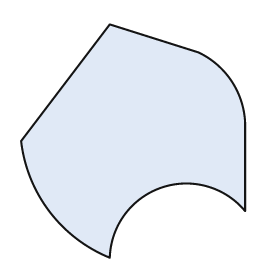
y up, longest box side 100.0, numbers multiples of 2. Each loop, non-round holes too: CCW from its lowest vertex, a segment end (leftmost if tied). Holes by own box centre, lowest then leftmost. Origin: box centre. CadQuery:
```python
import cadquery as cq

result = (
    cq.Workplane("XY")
    .moveTo(-10.0, -50.0)
    .threePointArc((12.0, -20.0), (48.0, -30.0))
    .lineTo(48.0, 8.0)
    .threePointArc((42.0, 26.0), (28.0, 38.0))
    .lineTo(-10.0, 50.0)
    .lineTo(-48.0, 0.0)
    .threePointArc((-36.0, -30.0), (-10.0, -50.0))
    .close()
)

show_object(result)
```